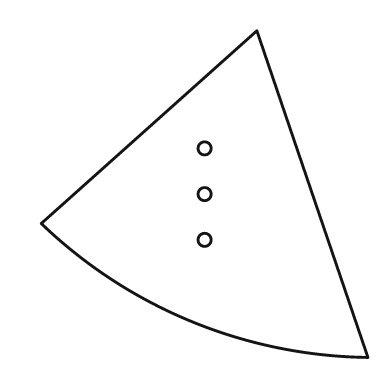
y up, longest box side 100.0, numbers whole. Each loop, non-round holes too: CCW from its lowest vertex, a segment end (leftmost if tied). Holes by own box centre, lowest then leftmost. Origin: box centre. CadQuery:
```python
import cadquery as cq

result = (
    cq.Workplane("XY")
    .moveTo(50.0, -50.0)
    .lineTo(16.0, 50.0)
    .lineTo(-50.0, -9.0)
    .threePointArc((-4.0, -39.0), (50.0, -50.0))
    .close()
    .moveTo(0.0, -14.0)
    .circle(2.0)
    .moveTo(0.0, 0.0)
    .circle(2.0)
    .moveTo(0.0, 14.0)
    .circle(2.0)
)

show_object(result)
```